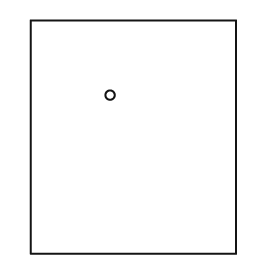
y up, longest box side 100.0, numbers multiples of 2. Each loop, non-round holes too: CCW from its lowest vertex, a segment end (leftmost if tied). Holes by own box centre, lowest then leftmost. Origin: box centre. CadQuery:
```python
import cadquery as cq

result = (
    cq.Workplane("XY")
    .moveTo(-44.0, -50.0)
    .lineTo(44.0, -50.0)
    .lineTo(44.0, 50.0)
    .lineTo(-44.0, 50.0)
    .close()
    .moveTo(-10.0, 18.0)
    .circle(2.0)
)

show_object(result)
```